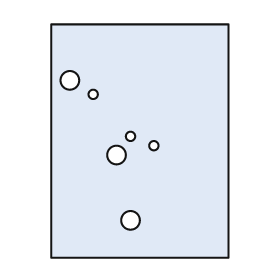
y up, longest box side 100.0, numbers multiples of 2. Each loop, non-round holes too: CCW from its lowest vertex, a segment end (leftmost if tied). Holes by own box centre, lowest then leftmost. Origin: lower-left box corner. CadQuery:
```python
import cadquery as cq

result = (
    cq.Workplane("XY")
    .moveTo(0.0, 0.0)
    .lineTo(76.0, 0.0)
    .lineTo(76.0, 100.0)
    .lineTo(0.0, 100.0)
    .close()
    .moveTo(34.0, 16.0)
    .circle(4.0)
    .moveTo(28.0, 44.0)
    .circle(4.0)
    .moveTo(44.0, 48.0)
    .circle(2.0)
    .moveTo(34.0, 52.0)
    .circle(2.0)
    .moveTo(18.0, 70.0)
    .circle(2.0)
    .moveTo(8.0, 76.0)
    .circle(4.0)
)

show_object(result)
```